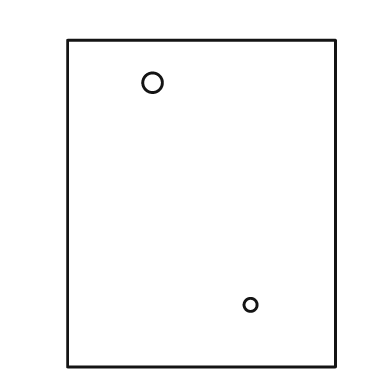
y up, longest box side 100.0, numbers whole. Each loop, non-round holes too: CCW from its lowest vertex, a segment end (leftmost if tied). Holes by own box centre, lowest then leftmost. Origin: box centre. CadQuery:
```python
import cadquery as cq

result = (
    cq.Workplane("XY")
    .moveTo(-41.0, -50.0)
    .lineTo(41.0, -50.0)
    .lineTo(41.0, 50.0)
    .lineTo(-41.0, 50.0)
    .close()
    .moveTo(15.0, -31.0)
    .circle(2.0)
    .moveTo(-15.0, 37.0)
    .circle(3.0)
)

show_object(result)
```